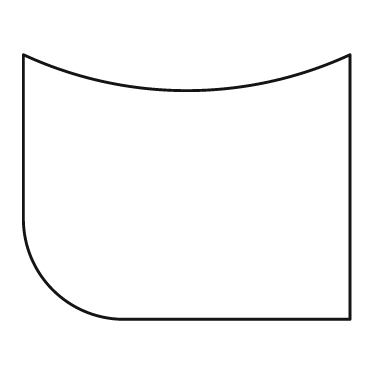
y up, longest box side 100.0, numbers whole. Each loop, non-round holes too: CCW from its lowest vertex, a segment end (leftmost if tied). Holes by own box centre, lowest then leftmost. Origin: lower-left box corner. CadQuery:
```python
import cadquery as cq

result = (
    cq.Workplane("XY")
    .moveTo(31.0, 0.0)
    .lineTo(100.0, 0.0)
    .lineTo(100.0, 81.0)
    .threePointArc((50.0, 70.0), (0.0, 81.0))
    .lineTo(0.0, 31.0)
    .threePointArc((9.0, 9.0), (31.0, 0.0))
    .close()
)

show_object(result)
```